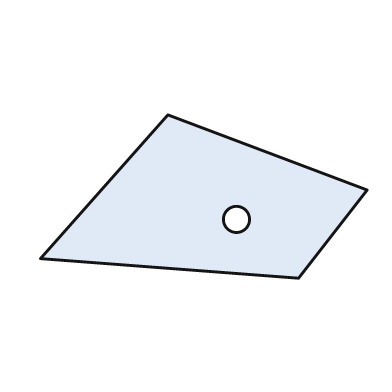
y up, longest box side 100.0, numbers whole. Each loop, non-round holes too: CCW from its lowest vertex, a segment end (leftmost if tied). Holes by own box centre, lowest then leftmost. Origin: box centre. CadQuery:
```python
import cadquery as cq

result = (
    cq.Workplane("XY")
    .moveTo(29.0, -25.0)
    .lineTo(50.0, 2.0)
    .lineTo(-11.0, 25.0)
    .lineTo(-50.0, -19.0)
    .close()
    .moveTo(10.0, -7.0)
    .circle(4.0)
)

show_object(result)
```